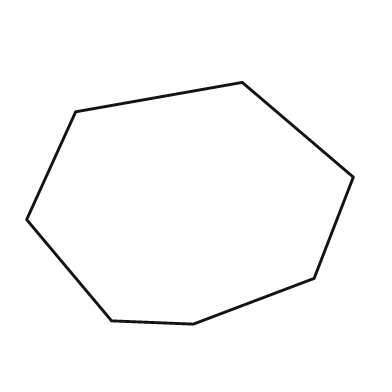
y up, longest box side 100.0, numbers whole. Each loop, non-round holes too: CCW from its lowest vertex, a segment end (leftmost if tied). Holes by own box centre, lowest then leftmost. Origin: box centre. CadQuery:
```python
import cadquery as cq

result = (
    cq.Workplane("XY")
    .moveTo(1.0, -37.0)
    .lineTo(38.0, -23.0)
    .lineTo(50.0, 8.0)
    .lineTo(16.0, 37.0)
    .lineTo(-35.0, 28.0)
    .lineTo(-50.0, -5.0)
    .lineTo(-24.0, -36.0)
    .close()
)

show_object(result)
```